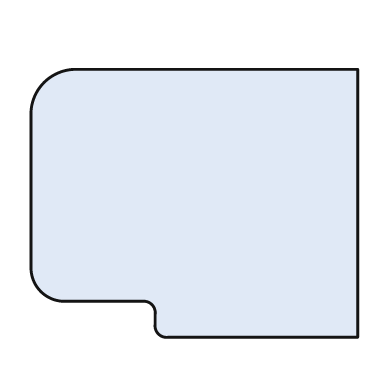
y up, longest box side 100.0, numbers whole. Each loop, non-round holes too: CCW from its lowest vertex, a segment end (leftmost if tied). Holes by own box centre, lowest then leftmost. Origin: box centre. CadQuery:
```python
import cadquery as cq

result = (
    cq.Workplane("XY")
    .moveTo(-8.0, -41.0)
    .lineTo(50.0, -41.0)
    .lineTo(50.0, 41.0)
    .lineTo(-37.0, 41.0)
    .threePointArc((-46.0, 37.0), (-50.0, 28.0))
    .lineTo(-50.0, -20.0)
    .threePointArc((-47.0, -27.0), (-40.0, -30.0))
    .lineTo(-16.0, -30.0)
    .threePointArc((-13.0, -31.0), (-12.0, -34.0))
    .lineTo(-12.0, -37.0)
    .threePointArc((-11.0, -40.0), (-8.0, -41.0))
    .close()
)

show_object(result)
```